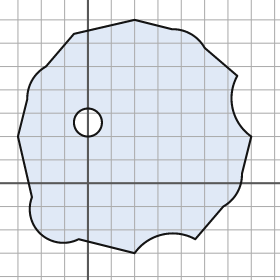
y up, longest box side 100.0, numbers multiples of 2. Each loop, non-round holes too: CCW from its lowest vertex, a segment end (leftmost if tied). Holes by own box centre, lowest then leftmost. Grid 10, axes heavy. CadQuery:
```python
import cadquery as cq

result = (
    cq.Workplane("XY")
    .moveTo(20.0, -30.0)
    .threePointArc((32.0, -22.0), (46.0, -24.0))
    .lineTo(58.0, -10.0)
    .threePointArc((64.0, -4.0), (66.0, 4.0))
    .lineTo(70.0, 20.0)
    .threePointArc((62.0, 32.0), (64.0, 46.0))
    .lineTo(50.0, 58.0)
    .threePointArc((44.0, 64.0), (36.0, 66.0))
    .lineTo(20.0, 70.0)
    .lineTo(-6.0, 64.0)
    .lineTo(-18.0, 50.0)
    .threePointArc((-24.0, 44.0), (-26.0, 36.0))
    .lineTo(-30.0, 20.0)
    .lineTo(-24.0, -6.0)
    .threePointArc((-20.0, -22.0), (-4.0, -24.0))
    .close()
    .moveTo(0.0, 26.0)
    .circle(6.0)
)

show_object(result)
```